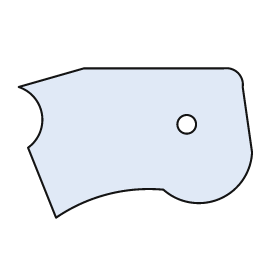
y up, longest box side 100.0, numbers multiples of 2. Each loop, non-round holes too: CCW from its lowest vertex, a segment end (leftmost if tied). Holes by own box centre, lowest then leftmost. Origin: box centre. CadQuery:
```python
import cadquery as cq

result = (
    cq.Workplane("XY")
    .moveTo(-34.0, -32.0)
    .threePointArc((-12.0, -22.0), (12.0, -20.0))
    .threePointArc((36.0, -24.0), (50.0, -4.0))
    .lineTo(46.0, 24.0)
    .threePointArc((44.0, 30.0), (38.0, 32.0))
    .lineTo(-22.0, 32.0)
    .lineTo(-50.0, 24.0)
    .threePointArc((-40.0, 12.0), (-46.0, -2.0))
    .close()
    .moveTo(22.0, 8.0)
    .circle(4.0)
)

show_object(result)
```